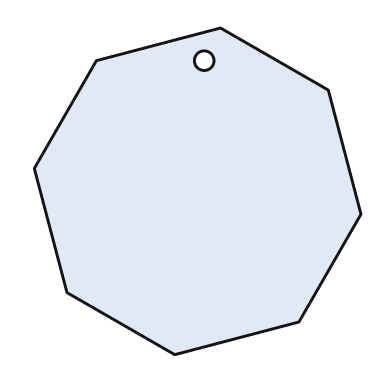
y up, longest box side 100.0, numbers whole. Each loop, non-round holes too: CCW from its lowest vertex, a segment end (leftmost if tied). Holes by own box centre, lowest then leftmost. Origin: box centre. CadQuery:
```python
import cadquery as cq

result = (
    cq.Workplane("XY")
    .moveTo(-7.0, -50.0)
    .lineTo(31.0, -40.0)
    .lineTo(50.0, -7.0)
    .lineTo(40.0, 31.0)
    .lineTo(7.0, 50.0)
    .lineTo(-31.0, 40.0)
    .lineTo(-50.0, 7.0)
    .lineTo(-40.0, -31.0)
    .close()
    .moveTo(2.0, 40.0)
    .circle(3.0)
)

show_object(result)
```